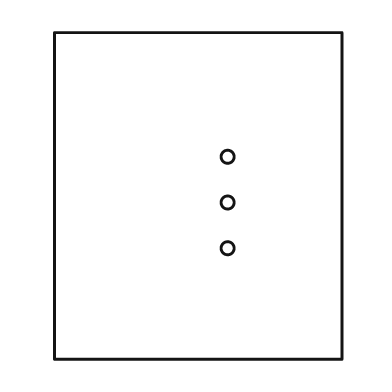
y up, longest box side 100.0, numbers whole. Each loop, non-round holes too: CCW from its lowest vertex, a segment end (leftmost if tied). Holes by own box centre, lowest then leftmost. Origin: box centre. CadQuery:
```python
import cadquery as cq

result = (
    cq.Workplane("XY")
    .moveTo(-44.0, -50.0)
    .lineTo(44.0, -50.0)
    .lineTo(44.0, 50.0)
    .lineTo(-44.0, 50.0)
    .close()
    .moveTo(9.0, -16.0)
    .circle(2.0)
    .moveTo(9.0, -2.0)
    .circle(2.0)
    .moveTo(9.0, 12.0)
    .circle(2.0)
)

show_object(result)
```